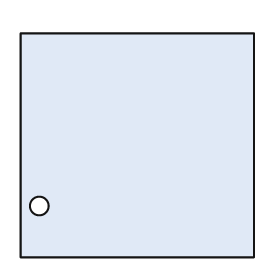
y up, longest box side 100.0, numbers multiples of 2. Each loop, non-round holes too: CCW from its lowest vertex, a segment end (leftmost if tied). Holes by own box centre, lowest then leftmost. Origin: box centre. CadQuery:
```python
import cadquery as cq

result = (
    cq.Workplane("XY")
    .moveTo(-50.0, -48.0)
    .lineTo(50.0, -48.0)
    .lineTo(50.0, 48.0)
    .lineTo(-50.0, 48.0)
    .close()
    .moveTo(-42.0, -26.0)
    .circle(4.0)
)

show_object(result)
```